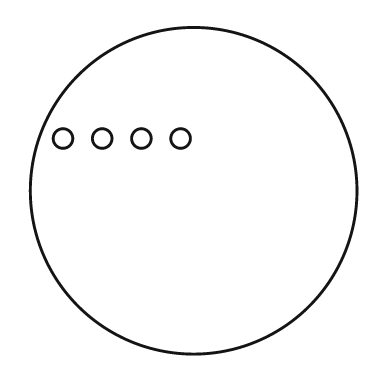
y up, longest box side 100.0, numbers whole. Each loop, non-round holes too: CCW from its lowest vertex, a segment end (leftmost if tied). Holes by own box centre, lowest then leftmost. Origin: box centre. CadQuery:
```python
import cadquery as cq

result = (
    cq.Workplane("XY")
    .moveTo(0.0, 0.0)
    .circle(50.0)
    .moveTo(-40.0, 16.0)
    .circle(3.0)
    .moveTo(-28.0, 16.0)
    .circle(3.0)
    .moveTo(-16.0, 16.0)
    .circle(3.0)
    .moveTo(-4.0, 16.0)
    .circle(3.0)
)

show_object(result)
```